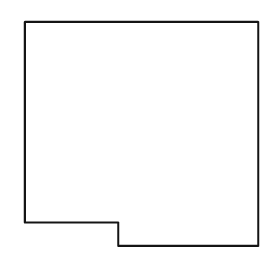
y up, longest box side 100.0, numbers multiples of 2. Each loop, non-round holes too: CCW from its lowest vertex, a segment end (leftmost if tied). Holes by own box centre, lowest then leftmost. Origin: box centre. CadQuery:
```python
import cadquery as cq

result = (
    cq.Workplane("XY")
    .moveTo(-10.0, -48.0)
    .lineTo(50.0, -48.0)
    .lineTo(50.0, 48.0)
    .lineTo(-50.0, 48.0)
    .lineTo(-50.0, -38.0)
    .lineTo(-10.0, -38.0)
    .close()
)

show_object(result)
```